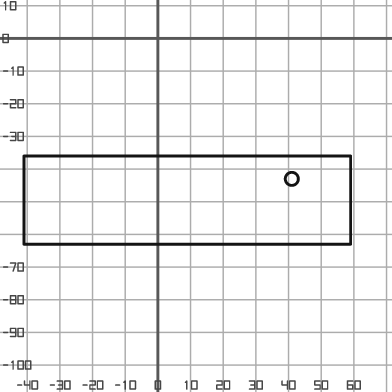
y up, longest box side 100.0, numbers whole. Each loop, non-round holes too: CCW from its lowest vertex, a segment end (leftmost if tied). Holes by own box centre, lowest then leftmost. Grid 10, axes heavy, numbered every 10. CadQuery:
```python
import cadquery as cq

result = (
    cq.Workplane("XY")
    .moveTo(-41.0, -63.0)
    .lineTo(59.0, -63.0)
    .lineTo(59.0, -36.0)
    .lineTo(-41.0, -36.0)
    .close()
    .moveTo(41.0, -43.0)
    .circle(2.0)
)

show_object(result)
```